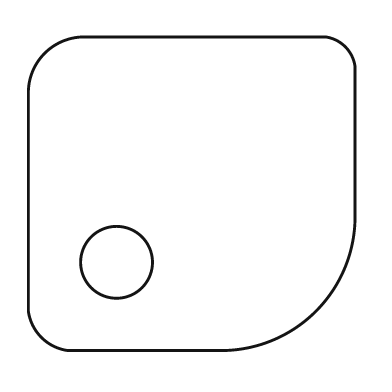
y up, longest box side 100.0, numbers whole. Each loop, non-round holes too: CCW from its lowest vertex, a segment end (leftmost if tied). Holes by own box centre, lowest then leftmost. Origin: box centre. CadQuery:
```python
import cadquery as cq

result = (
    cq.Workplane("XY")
    .moveTo(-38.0, -48.0)
    .lineTo(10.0, -48.0)
    .threePointArc((38.0, -36.0), (50.0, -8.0))
    .lineTo(50.0, 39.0)
    .threePointArc((47.0, 45.0), (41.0, 48.0))
    .lineTo(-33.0, 48.0)
    .threePointArc((-45.0, 43.0), (-50.0, 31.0))
    .lineTo(-50.0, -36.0)
    .threePointArc((-46.0, -44.0), (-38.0, -48.0))
    .close()
    .moveTo(-23.0, -21.0)
    .circle(11.0)
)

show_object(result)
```